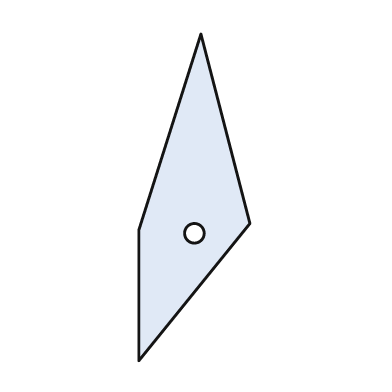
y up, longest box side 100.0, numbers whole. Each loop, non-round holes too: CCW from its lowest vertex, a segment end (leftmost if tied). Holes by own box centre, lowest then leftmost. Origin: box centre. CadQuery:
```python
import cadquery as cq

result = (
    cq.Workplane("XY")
    .moveTo(-17.0, -50.0)
    .lineTo(17.0, -8.0)
    .lineTo(2.0, 50.0)
    .lineTo(-17.0, -10.0)
    .close()
    .moveTo(0.0, -11.0)
    .circle(3.0)
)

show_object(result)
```